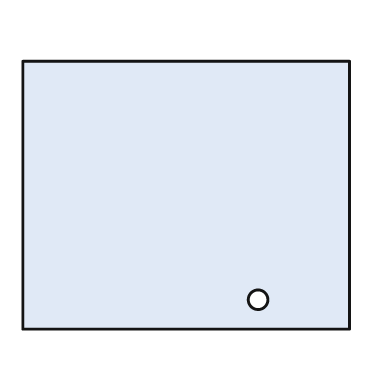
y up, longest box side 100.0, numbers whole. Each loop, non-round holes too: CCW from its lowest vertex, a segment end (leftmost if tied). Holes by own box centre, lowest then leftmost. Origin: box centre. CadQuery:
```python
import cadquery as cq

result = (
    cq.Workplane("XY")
    .moveTo(-50.0, -41.0)
    .lineTo(50.0, -41.0)
    .lineTo(50.0, 41.0)
    .lineTo(-50.0, 41.0)
    .close()
    .moveTo(22.0, -32.0)
    .circle(3.0)
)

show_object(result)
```